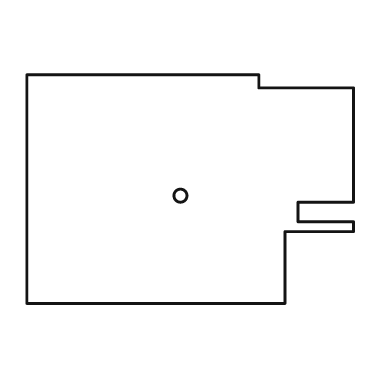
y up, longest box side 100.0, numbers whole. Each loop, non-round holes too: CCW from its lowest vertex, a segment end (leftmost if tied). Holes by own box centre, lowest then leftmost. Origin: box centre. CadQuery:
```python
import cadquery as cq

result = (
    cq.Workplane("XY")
    .moveTo(-50.0, -35.0)
    .lineTo(29.0, -35.0)
    .lineTo(29.0, -13.0)
    .lineTo(50.0, -13.0)
    .lineTo(50.0, -10.0)
    .lineTo(33.0, -10.0)
    .lineTo(33.0, -4.0)
    .lineTo(50.0, -4.0)
    .lineTo(50.0, 31.0)
    .lineTo(21.0, 31.0)
    .lineTo(21.0, 35.0)
    .lineTo(-50.0, 35.0)
    .close()
    .moveTo(-3.0, -2.0)
    .circle(2.0)
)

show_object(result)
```